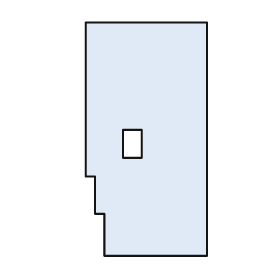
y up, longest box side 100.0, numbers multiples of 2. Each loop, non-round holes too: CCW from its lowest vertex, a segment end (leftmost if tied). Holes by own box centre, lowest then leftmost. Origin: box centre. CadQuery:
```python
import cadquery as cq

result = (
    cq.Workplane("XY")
    .moveTo(-18.0, -50.0)
    .lineTo(26.0, -50.0)
    .lineTo(26.0, 50.0)
    .lineTo(-26.0, 50.0)
    .lineTo(-26.0, -16.0)
    .lineTo(-22.0, -16.0)
    .lineTo(-22.0, -32.0)
    .lineTo(-18.0, -32.0)
    .close()
    .moveTo(-10.0, -8.0)
    .lineTo(-2.0, -8.0)
    .lineTo(-2.0, 4.0)
    .lineTo(-10.0, 4.0)
    .close()
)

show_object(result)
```